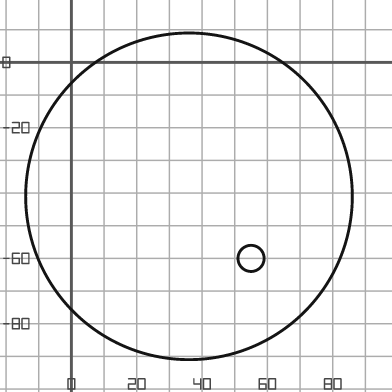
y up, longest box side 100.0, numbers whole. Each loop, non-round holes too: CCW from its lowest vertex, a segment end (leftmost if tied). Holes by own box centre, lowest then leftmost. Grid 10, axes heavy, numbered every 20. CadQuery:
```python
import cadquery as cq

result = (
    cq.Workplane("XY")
    .moveTo(36.0, -41.0)
    .circle(50.0)
    .moveTo(55.0, -60.0)
    .circle(4.0)
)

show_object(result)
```